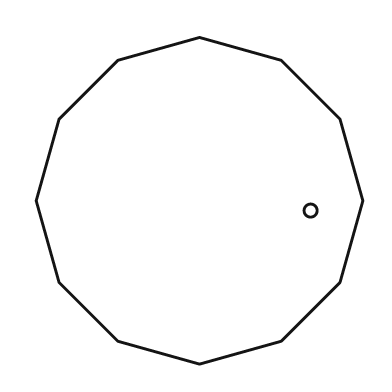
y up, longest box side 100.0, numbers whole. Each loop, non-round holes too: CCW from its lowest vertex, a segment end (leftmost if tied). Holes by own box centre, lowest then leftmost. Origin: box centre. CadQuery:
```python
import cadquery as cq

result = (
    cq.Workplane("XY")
    .moveTo(0.0, -50.0)
    .lineTo(25.0, -43.0)
    .lineTo(43.0, -25.0)
    .lineTo(50.0, 0.0)
    .lineTo(43.0, 25.0)
    .lineTo(25.0, 43.0)
    .lineTo(0.0, 50.0)
    .lineTo(-25.0, 43.0)
    .lineTo(-43.0, 25.0)
    .lineTo(-50.0, 0.0)
    .lineTo(-43.0, -25.0)
    .lineTo(-25.0, -43.0)
    .close()
    .moveTo(34.0, -3.0)
    .circle(2.0)
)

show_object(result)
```